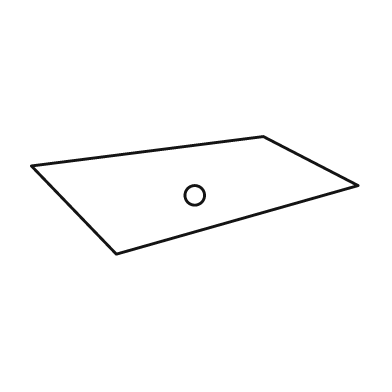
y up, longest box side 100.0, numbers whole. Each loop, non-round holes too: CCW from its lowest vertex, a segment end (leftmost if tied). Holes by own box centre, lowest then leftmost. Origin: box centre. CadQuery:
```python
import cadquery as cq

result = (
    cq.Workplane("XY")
    .moveTo(-24.0, -18.0)
    .lineTo(50.0, 3.0)
    .lineTo(21.0, 18.0)
    .lineTo(-50.0, 9.0)
    .close()
    .moveTo(0.0, 0.0)
    .circle(3.0)
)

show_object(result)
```